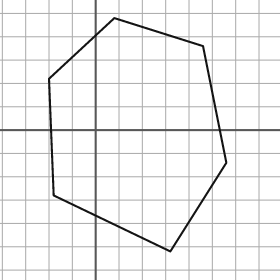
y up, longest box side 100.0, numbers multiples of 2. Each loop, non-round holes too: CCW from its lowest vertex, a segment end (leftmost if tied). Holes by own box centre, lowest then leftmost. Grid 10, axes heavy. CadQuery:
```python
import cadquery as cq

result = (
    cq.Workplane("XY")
    .moveTo(32.0, -52.0)
    .lineTo(56.0, -14.0)
    .lineTo(46.0, 36.0)
    .lineTo(8.0, 48.0)
    .lineTo(-20.0, 22.0)
    .lineTo(-18.0, -28.0)
    .close()
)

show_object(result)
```